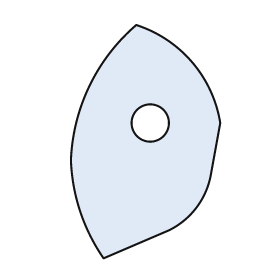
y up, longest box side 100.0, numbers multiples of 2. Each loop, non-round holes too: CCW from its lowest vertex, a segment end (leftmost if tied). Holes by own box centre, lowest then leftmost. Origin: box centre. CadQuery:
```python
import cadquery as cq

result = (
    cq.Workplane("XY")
    .moveTo(-18.0, -50.0)
    .lineTo(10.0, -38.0)
    .threePointArc((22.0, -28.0), (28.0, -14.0))
    .lineTo(32.0, 8.0)
    .threePointArc((20.0, 34.0), (-4.0, 50.0))
    .threePointArc((-24.0, 24.0), (-32.0, -8.0))
    .threePointArc((-28.0, -30.0), (-18.0, -50.0))
    .close()
    .moveTo(2.0, 8.0)
    .circle(8.0)
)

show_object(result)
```